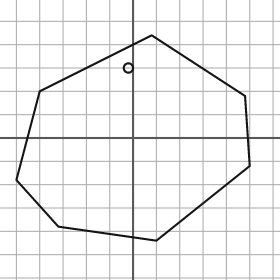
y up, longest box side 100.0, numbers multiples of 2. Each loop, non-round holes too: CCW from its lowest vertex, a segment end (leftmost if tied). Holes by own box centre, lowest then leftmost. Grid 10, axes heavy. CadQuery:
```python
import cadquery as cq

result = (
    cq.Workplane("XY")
    .moveTo(10.0, -44.0)
    .lineTo(50.0, -12.0)
    .lineTo(48.0, 18.0)
    .lineTo(8.0, 44.0)
    .lineTo(-40.0, 20.0)
    .lineTo(-50.0, -18.0)
    .lineTo(-32.0, -38.0)
    .close()
    .moveTo(-2.0, 30.0)
    .circle(2.0)
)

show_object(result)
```